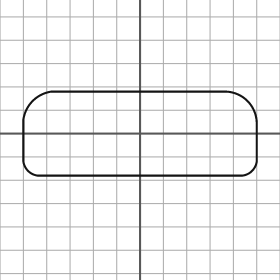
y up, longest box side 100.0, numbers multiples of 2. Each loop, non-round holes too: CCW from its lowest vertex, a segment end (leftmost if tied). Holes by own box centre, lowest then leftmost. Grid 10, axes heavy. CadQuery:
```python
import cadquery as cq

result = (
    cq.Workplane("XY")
    .moveTo(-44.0, -18.0)
    .lineTo(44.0, -18.0)
    .threePointArc((48.0, -16.0), (50.0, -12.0))
    .lineTo(50.0, 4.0)
    .threePointArc((46.0, 14.0), (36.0, 18.0))
    .lineTo(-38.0, 18.0)
    .threePointArc((-46.0, 14.0), (-50.0, 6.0))
    .lineTo(-50.0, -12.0)
    .threePointArc((-48.0, -16.0), (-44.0, -18.0))
    .close()
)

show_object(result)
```